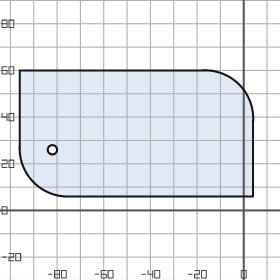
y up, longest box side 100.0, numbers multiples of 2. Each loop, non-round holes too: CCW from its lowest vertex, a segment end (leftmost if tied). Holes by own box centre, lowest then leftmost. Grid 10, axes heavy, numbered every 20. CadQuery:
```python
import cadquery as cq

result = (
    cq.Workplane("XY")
    .moveTo(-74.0, 6.0)
    .lineTo(4.0, 6.0)
    .lineTo(4.0, 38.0)
    .threePointArc((-2.0, 54.0), (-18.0, 60.0))
    .lineTo(-96.0, 60.0)
    .lineTo(-96.0, 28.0)
    .threePointArc((-90.0, 12.0), (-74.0, 6.0))
    .close()
    .moveTo(-82.0, 26.0)
    .circle(2.0)
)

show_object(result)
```